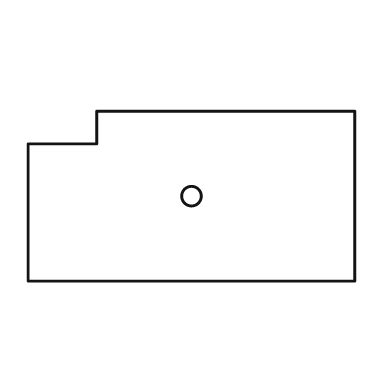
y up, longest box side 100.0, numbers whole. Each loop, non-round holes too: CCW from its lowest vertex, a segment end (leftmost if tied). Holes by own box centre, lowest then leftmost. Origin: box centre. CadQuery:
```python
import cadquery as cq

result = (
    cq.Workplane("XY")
    .moveTo(-50.0, -26.0)
    .lineTo(50.0, -26.0)
    .lineTo(50.0, 26.0)
    .lineTo(-29.0, 26.0)
    .lineTo(-29.0, 16.0)
    .lineTo(-50.0, 16.0)
    .close()
    .moveTo(0.0, 0.0)
    .circle(3.0)
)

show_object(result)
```